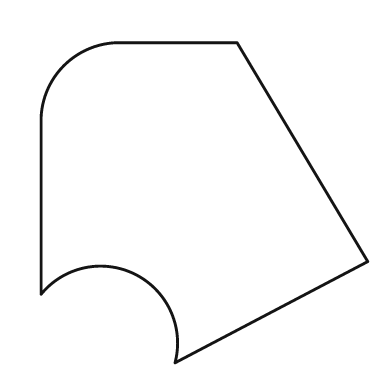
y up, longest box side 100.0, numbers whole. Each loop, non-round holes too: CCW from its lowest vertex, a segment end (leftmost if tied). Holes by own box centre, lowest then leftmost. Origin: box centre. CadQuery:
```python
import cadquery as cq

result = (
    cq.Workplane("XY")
    .moveTo(-9.0, -49.0)
    .lineTo(50.0, -18.0)
    .lineTo(10.0, 49.0)
    .lineTo(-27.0, 49.0)
    .threePointArc((-43.0, 42.0), (-50.0, 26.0))
    .lineTo(-50.0, -28.0)
    .threePointArc((-21.0, -22.0), (-9.0, -49.0))
    .close()
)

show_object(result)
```